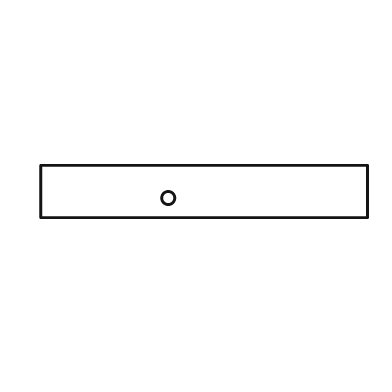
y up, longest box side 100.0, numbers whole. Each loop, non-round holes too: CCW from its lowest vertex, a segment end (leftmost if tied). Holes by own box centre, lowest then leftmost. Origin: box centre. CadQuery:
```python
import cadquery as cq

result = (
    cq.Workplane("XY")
    .moveTo(-50.0, -8.0)
    .lineTo(50.0, -8.0)
    .lineTo(50.0, 8.0)
    .lineTo(-50.0, 8.0)
    .close()
    .moveTo(-11.0, -2.0)
    .circle(2.0)
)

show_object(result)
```